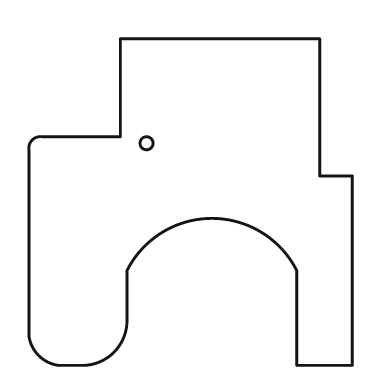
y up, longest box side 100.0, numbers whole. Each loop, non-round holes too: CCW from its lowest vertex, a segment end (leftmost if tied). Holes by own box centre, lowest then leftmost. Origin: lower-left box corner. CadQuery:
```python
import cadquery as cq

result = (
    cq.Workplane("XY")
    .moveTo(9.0, 0.0)
    .lineTo(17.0, 0.0)
    .threePointArc((26.0, 4.0), (30.0, 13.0))
    .lineTo(30.0, 29.0)
    .threePointArc((56.0, 45.0), (82.0, 29.0))
    .lineTo(82.0, 0.0)
    .lineTo(99.0, 0.0)
    .lineTo(99.0, 58.0)
    .lineTo(89.0, 58.0)
    .lineTo(89.0, 100.0)
    .lineTo(28.0, 100.0)
    .lineTo(28.0, 70.0)
    .lineTo(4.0, 70.0)
    .threePointArc((1.0, 69.0), (0.0, 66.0))
    .lineTo(0.0, 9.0)
    .threePointArc((3.0, 3.0), (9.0, 0.0))
    .close()
    .moveTo(36.0, 68.0)
    .circle(2.0)
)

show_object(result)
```